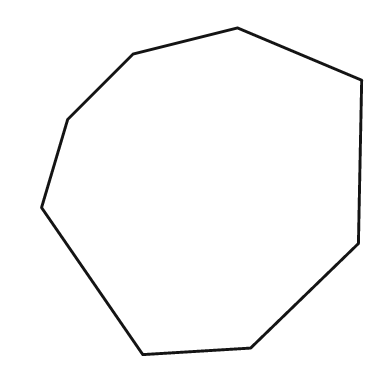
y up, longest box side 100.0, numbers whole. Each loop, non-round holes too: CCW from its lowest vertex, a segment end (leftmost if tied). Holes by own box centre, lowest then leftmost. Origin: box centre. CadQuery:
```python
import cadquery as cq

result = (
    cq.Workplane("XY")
    .moveTo(-18.0, -50.0)
    .lineTo(15.0, -48.0)
    .lineTo(48.0, -16.0)
    .lineTo(49.0, 34.0)
    .lineTo(11.0, 50.0)
    .lineTo(-21.0, 42.0)
    .lineTo(-41.0, 22.0)
    .lineTo(-49.0, -5.0)
    .close()
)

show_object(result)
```